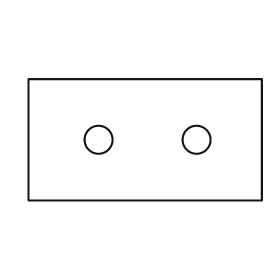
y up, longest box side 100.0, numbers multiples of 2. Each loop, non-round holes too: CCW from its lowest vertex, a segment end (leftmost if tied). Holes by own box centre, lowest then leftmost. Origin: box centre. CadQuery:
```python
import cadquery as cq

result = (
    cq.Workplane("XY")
    .moveTo(-50.0, -26.0)
    .lineTo(50.0, -26.0)
    .lineTo(50.0, 26.0)
    .lineTo(-50.0, 26.0)
    .close()
    .moveTo(-20.0, 0.0)
    .circle(6.0)
    .moveTo(22.0, 0.0)
    .circle(6.0)
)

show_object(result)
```